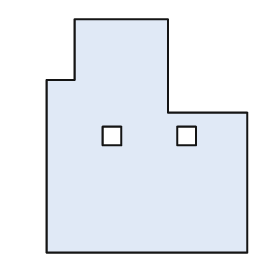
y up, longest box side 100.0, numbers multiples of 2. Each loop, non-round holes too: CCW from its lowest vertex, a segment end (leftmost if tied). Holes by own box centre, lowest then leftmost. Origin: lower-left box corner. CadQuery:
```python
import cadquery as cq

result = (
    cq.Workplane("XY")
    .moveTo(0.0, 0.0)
    .lineTo(86.0, 0.0)
    .lineTo(86.0, 60.0)
    .lineTo(52.0, 60.0)
    .lineTo(52.0, 100.0)
    .lineTo(12.0, 100.0)
    .lineTo(12.0, 74.0)
    .lineTo(0.0, 74.0)
    .close()
    .moveTo(24.0, 46.0)
    .lineTo(32.0, 46.0)
    .lineTo(32.0, 54.0)
    .lineTo(24.0, 54.0)
    .close()
    .moveTo(56.0, 46.0)
    .lineTo(64.0, 46.0)
    .lineTo(64.0, 54.0)
    .lineTo(56.0, 54.0)
    .close()
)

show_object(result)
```